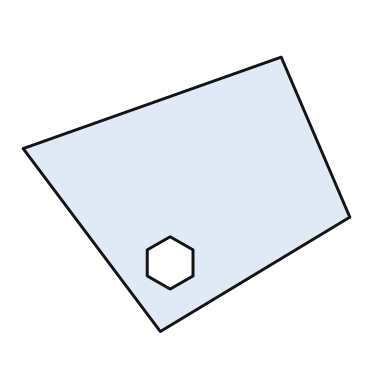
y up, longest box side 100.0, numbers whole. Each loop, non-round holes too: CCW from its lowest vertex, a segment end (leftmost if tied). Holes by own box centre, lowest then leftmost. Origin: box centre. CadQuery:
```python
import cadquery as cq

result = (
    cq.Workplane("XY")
    .moveTo(-8.0, -42.0)
    .lineTo(50.0, -7.0)
    .lineTo(29.0, 42.0)
    .lineTo(-50.0, 14.0)
    .close()
    .moveTo(-5.0, -29.0)
    .lineTo(2.0, -25.0)
    .lineTo(2.0, -17.0)
    .lineTo(-5.0, -13.0)
    .lineTo(-12.0, -17.0)
    .lineTo(-12.0, -25.0)
    .close()
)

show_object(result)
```